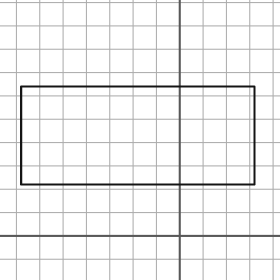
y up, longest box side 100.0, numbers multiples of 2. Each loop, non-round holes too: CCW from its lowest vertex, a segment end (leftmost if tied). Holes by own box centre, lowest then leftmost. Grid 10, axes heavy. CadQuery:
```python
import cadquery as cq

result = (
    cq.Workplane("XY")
    .moveTo(-68.0, 22.0)
    .lineTo(32.0, 22.0)
    .lineTo(32.0, 64.0)
    .lineTo(-68.0, 64.0)
    .close()
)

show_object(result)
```